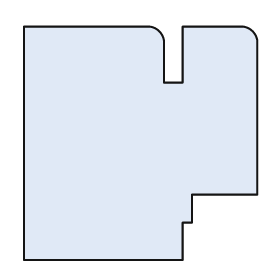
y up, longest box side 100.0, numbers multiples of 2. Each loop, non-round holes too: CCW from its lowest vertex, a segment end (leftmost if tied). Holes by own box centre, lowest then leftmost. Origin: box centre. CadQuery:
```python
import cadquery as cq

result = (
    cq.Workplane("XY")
    .moveTo(-50.0, -50.0)
    .lineTo(18.0, -50.0)
    .lineTo(18.0, -34.0)
    .lineTo(22.0, -34.0)
    .lineTo(22.0, -22.0)
    .lineTo(50.0, -22.0)
    .lineTo(50.0, 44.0)
    .threePointArc((48.0, 48.0), (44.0, 50.0))
    .lineTo(18.0, 50.0)
    .lineTo(18.0, 26.0)
    .lineTo(10.0, 26.0)
    .lineTo(10.0, 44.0)
    .threePointArc((8.0, 48.0), (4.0, 50.0))
    .lineTo(-50.0, 50.0)
    .close()
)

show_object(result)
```